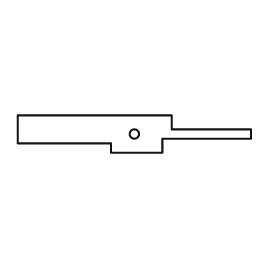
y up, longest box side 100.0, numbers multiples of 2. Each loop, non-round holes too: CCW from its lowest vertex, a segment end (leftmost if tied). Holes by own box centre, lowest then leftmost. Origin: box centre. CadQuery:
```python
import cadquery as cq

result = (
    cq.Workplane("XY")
    .moveTo(-10.0, -8.0)
    .lineTo(12.0, -8.0)
    .lineTo(12.0, -2.0)
    .lineTo(50.0, -2.0)
    .lineTo(50.0, 2.0)
    .lineTo(16.0, 2.0)
    .lineTo(16.0, 8.0)
    .lineTo(-50.0, 8.0)
    .lineTo(-50.0, -4.0)
    .lineTo(-10.0, -4.0)
    .close()
    .moveTo(0.0, 0.0)
    .circle(2.0)
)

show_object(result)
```